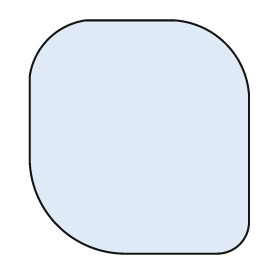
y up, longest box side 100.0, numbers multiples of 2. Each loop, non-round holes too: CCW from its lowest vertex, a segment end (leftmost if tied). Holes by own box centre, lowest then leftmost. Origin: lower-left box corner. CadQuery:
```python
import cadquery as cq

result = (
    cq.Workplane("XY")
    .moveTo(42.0, 0.0)
    .lineTo(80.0, 0.0)
    .threePointArc((90.0, 4.0), (94.0, 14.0))
    .lineTo(94.0, 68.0)
    .threePointArc((84.0, 90.0), (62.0, 100.0))
    .lineTo(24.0, 100.0)
    .threePointArc((8.0, 92.0), (0.0, 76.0))
    .lineTo(0.0, 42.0)
    .threePointArc((12.0, 12.0), (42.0, 0.0))
    .close()
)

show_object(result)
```